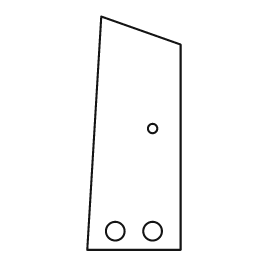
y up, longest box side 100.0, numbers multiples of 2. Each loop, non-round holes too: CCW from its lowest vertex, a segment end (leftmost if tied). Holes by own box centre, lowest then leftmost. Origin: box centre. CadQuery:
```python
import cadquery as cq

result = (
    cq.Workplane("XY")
    .moveTo(-20.0, -50.0)
    .lineTo(20.0, -50.0)
    .lineTo(20.0, 38.0)
    .lineTo(-14.0, 50.0)
    .close()
    .moveTo(-8.0, -42.0)
    .circle(4.0)
    .moveTo(8.0, -42.0)
    .circle(4.0)
    .moveTo(8.0, 2.0)
    .circle(2.0)
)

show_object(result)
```